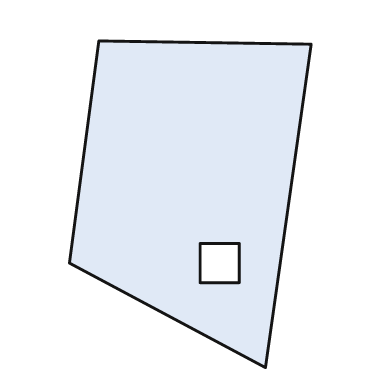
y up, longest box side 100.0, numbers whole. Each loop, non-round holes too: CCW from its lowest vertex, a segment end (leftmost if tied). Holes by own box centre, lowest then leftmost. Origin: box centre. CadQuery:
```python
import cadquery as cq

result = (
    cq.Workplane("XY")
    .moveTo(23.0, -50.0)
    .lineTo(37.0, 49.0)
    .lineTo(-28.0, 50.0)
    .lineTo(-37.0, -18.0)
    .close()
    .moveTo(3.0, -24.0)
    .lineTo(15.0, -24.0)
    .lineTo(15.0, -12.0)
    .lineTo(3.0, -12.0)
    .close()
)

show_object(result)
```